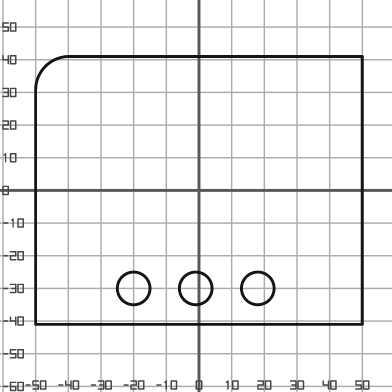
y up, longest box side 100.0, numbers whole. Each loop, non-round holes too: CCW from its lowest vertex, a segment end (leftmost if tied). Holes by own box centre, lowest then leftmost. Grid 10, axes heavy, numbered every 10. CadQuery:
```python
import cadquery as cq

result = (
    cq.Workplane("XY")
    .moveTo(-50.0, -41.0)
    .lineTo(50.0, -41.0)
    .lineTo(50.0, 41.0)
    .lineTo(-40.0, 41.0)
    .threePointArc((-47.0, 38.0), (-50.0, 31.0))
    .close()
    .moveTo(-20.0, -30.0)
    .circle(5.0)
    .moveTo(-1.0, -30.0)
    .circle(5.0)
    .moveTo(18.0, -30.0)
    .circle(5.0)
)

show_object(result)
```